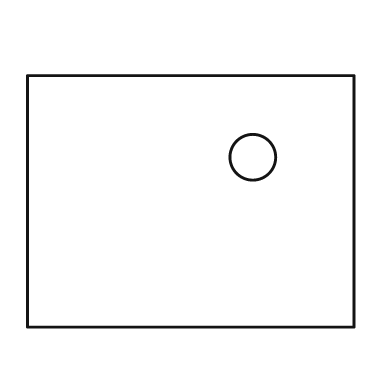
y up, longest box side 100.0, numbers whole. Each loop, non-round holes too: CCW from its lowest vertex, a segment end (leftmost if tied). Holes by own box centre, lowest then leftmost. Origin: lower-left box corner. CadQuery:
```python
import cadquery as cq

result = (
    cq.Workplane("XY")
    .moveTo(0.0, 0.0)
    .lineTo(100.0, 0.0)
    .lineTo(100.0, 77.0)
    .lineTo(0.0, 77.0)
    .close()
    .moveTo(69.0, 52.0)
    .circle(7.0)
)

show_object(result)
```